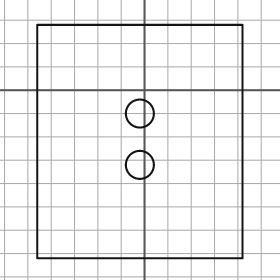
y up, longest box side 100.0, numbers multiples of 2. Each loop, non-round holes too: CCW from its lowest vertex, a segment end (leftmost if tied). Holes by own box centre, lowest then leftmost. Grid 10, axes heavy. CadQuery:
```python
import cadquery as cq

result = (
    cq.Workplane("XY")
    .moveTo(-46.0, -72.0)
    .lineTo(42.0, -72.0)
    .lineTo(42.0, 28.0)
    .lineTo(-46.0, 28.0)
    .close()
    .moveTo(-2.0, -32.0)
    .circle(6.0)
    .moveTo(-2.0, -10.0)
    .circle(6.0)
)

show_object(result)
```